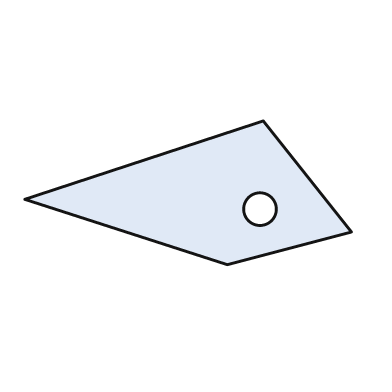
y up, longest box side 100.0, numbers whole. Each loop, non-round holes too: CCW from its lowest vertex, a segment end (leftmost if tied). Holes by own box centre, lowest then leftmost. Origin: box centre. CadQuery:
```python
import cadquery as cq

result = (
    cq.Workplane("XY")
    .moveTo(12.0, -22.0)
    .lineTo(50.0, -12.0)
    .lineTo(23.0, 22.0)
    .lineTo(-50.0, -2.0)
    .close()
    .moveTo(22.0, -5.0)
    .circle(5.0)
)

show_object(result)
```